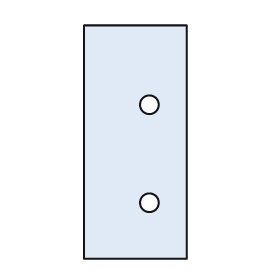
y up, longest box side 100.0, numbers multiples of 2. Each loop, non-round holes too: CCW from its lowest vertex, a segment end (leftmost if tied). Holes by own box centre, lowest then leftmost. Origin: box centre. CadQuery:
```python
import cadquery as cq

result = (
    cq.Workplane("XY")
    .moveTo(-22.0, -50.0)
    .lineTo(22.0, -50.0)
    .lineTo(22.0, 50.0)
    .lineTo(-22.0, 50.0)
    .close()
    .moveTo(6.0, -26.0)
    .circle(4.0)
    .moveTo(6.0, 16.0)
    .circle(4.0)
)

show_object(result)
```